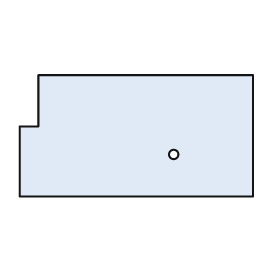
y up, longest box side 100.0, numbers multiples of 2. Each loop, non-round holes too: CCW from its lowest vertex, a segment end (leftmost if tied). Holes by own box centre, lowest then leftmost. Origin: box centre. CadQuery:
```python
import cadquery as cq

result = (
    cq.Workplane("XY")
    .moveTo(-50.0, -26.0)
    .lineTo(50.0, -26.0)
    .lineTo(50.0, 26.0)
    .lineTo(-42.0, 26.0)
    .lineTo(-42.0, 4.0)
    .lineTo(-50.0, 4.0)
    .close()
    .moveTo(16.0, -8.0)
    .circle(2.0)
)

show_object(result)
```